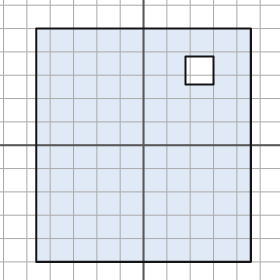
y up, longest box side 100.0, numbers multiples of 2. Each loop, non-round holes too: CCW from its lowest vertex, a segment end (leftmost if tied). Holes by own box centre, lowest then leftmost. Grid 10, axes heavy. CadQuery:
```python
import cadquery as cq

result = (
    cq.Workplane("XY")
    .moveTo(-46.0, -50.0)
    .lineTo(46.0, -50.0)
    .lineTo(46.0, 50.0)
    .lineTo(-46.0, 50.0)
    .close()
    .moveTo(18.0, 26.0)
    .lineTo(30.0, 26.0)
    .lineTo(30.0, 38.0)
    .lineTo(18.0, 38.0)
    .close()
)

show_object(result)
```